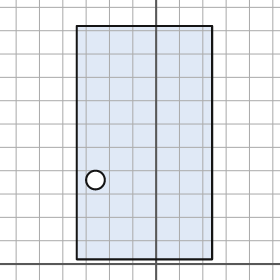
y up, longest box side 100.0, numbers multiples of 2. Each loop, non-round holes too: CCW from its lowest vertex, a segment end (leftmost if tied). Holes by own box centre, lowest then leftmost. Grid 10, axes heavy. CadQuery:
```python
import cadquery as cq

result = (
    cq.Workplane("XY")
    .moveTo(-34.0, 2.0)
    .lineTo(24.0, 2.0)
    .lineTo(24.0, 102.0)
    .lineTo(-34.0, 102.0)
    .close()
    .moveTo(-26.0, 36.0)
    .circle(4.0)
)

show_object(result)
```